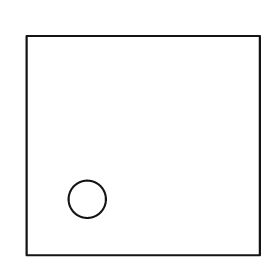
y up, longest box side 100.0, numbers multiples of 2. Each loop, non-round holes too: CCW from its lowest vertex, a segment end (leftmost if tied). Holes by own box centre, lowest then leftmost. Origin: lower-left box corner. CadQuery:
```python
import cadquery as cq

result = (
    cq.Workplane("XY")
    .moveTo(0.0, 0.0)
    .lineTo(100.0, 0.0)
    .lineTo(100.0, 94.0)
    .lineTo(0.0, 94.0)
    .close()
    .moveTo(26.0, 24.0)
    .circle(8.0)
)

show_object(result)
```